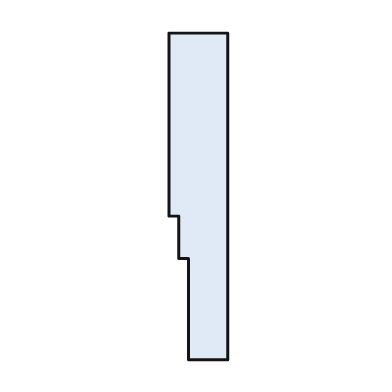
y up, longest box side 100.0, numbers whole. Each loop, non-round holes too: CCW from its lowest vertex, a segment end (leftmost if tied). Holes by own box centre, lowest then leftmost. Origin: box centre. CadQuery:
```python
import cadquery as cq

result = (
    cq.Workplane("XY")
    .moveTo(-3.0, -50.0)
    .lineTo(9.0, -50.0)
    .lineTo(9.0, 50.0)
    .lineTo(-9.0, 50.0)
    .lineTo(-9.0, -6.0)
    .lineTo(-6.0, -6.0)
    .lineTo(-6.0, -19.0)
    .lineTo(-3.0, -19.0)
    .close()
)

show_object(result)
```